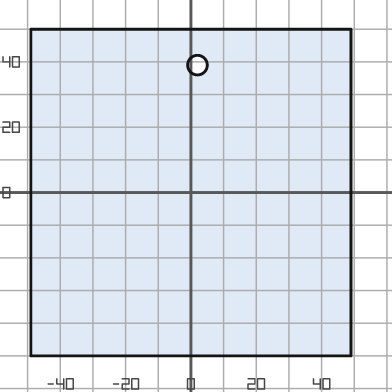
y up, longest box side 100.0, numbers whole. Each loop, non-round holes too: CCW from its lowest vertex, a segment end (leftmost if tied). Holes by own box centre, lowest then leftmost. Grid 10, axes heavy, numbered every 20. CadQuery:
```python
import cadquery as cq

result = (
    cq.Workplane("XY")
    .moveTo(-49.0, -50.0)
    .lineTo(49.0, -50.0)
    .lineTo(49.0, 50.0)
    .lineTo(-49.0, 50.0)
    .close()
    .moveTo(2.0, 39.0)
    .circle(3.0)
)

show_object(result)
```